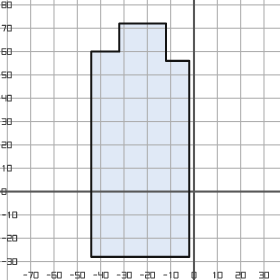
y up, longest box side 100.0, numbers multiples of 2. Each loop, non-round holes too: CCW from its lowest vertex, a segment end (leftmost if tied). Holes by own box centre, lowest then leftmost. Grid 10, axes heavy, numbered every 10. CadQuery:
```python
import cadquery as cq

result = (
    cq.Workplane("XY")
    .moveTo(-44.0, -28.0)
    .lineTo(-2.0, -28.0)
    .lineTo(-2.0, 56.0)
    .lineTo(-12.0, 56.0)
    .lineTo(-12.0, 72.0)
    .lineTo(-32.0, 72.0)
    .lineTo(-32.0, 60.0)
    .lineTo(-44.0, 60.0)
    .close()
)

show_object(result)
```